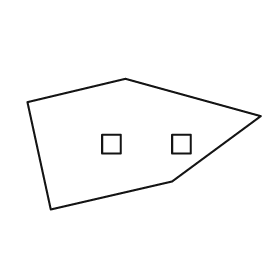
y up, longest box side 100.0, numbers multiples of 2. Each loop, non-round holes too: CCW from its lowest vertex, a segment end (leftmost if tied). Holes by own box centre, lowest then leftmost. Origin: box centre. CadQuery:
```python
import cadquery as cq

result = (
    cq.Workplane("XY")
    .moveTo(-40.0, -28.0)
    .lineTo(12.0, -16.0)
    .lineTo(50.0, 12.0)
    .lineTo(-8.0, 28.0)
    .lineTo(-50.0, 18.0)
    .close()
    .moveTo(-18.0, -4.0)
    .lineTo(-10.0, -4.0)
    .lineTo(-10.0, 4.0)
    .lineTo(-18.0, 4.0)
    .close()
    .moveTo(12.0, -4.0)
    .lineTo(20.0, -4.0)
    .lineTo(20.0, 4.0)
    .lineTo(12.0, 4.0)
    .close()
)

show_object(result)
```